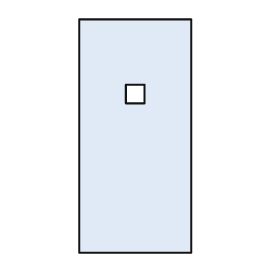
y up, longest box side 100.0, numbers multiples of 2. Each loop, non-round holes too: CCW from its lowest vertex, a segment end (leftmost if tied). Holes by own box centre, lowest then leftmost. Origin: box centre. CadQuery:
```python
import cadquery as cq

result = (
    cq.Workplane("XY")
    .moveTo(-24.0, -50.0)
    .lineTo(24.0, -50.0)
    .lineTo(24.0, 50.0)
    .lineTo(-24.0, 50.0)
    .close()
    .moveTo(-4.0, 14.0)
    .lineTo(4.0, 14.0)
    .lineTo(4.0, 22.0)
    .lineTo(-4.0, 22.0)
    .close()
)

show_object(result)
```